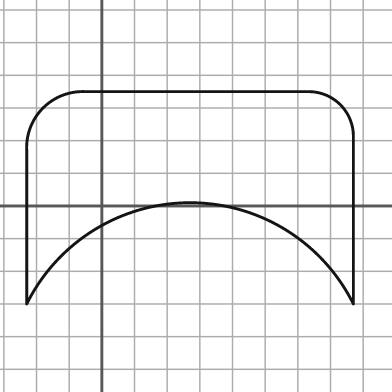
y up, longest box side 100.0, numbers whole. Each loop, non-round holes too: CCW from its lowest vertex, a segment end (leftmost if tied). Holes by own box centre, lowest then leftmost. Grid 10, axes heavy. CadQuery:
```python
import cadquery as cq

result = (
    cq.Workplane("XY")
    .moveTo(-23.0, -30.0)
    .threePointArc((27.0, 1.0), (77.0, -30.0))
    .lineTo(77.0, 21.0)
    .threePointArc((73.0, 31.0), (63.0, 35.0))
    .lineTo(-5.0, 35.0)
    .threePointArc((-18.0, 30.0), (-23.0, 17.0))
    .close()
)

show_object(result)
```